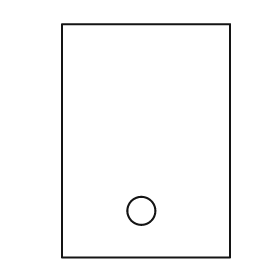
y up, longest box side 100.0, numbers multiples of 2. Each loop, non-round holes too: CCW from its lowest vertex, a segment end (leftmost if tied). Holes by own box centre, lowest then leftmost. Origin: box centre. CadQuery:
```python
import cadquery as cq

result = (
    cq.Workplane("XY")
    .moveTo(-36.0, -50.0)
    .lineTo(36.0, -50.0)
    .lineTo(36.0, 50.0)
    .lineTo(-36.0, 50.0)
    .close()
    .moveTo(-2.0, -30.0)
    .circle(6.0)
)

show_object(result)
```